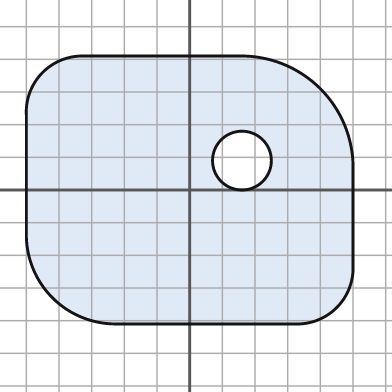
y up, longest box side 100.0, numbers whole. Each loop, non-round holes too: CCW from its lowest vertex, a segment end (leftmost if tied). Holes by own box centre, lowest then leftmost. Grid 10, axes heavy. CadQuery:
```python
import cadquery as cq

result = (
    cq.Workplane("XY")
    .moveTo(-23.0, -41.0)
    .lineTo(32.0, -41.0)
    .threePointArc((45.0, -36.0), (50.0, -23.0))
    .lineTo(50.0, 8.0)
    .threePointArc((40.0, 31.0), (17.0, 41.0))
    .lineTo(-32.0, 41.0)
    .threePointArc((-45.0, 36.0), (-50.0, 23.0))
    .lineTo(-50.0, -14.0)
    .threePointArc((-42.0, -33.0), (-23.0, -41.0))
    .close()
    .moveTo(16.0, 9.0)
    .circle(9.0)
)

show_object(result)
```